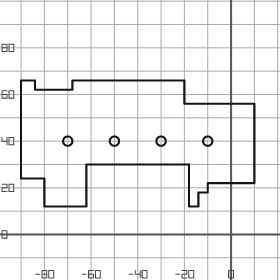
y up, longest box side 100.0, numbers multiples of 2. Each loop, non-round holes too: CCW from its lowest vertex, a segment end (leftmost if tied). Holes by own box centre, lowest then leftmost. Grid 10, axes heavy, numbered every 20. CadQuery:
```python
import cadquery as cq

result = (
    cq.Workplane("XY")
    .moveTo(-80.0, 12.0)
    .lineTo(-62.0, 12.0)
    .lineTo(-62.0, 30.0)
    .lineTo(-18.0, 30.0)
    .lineTo(-18.0, 12.0)
    .lineTo(-14.0, 12.0)
    .lineTo(-14.0, 18.0)
    .lineTo(-10.0, 18.0)
    .lineTo(-10.0, 22.0)
    .lineTo(10.0, 22.0)
    .lineTo(10.0, 56.0)
    .lineTo(-20.0, 56.0)
    .lineTo(-20.0, 66.0)
    .lineTo(-68.0, 66.0)
    .lineTo(-68.0, 62.0)
    .lineTo(-84.0, 62.0)
    .lineTo(-84.0, 66.0)
    .lineTo(-90.0, 66.0)
    .lineTo(-90.0, 24.0)
    .lineTo(-80.0, 24.0)
    .close()
    .moveTo(-70.0, 40.0)
    .circle(2.0)
    .moveTo(-50.0, 40.0)
    .circle(2.0)
    .moveTo(-30.0, 40.0)
    .circle(2.0)
    .moveTo(-10.0, 40.0)
    .circle(2.0)
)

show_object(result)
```